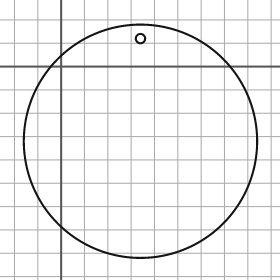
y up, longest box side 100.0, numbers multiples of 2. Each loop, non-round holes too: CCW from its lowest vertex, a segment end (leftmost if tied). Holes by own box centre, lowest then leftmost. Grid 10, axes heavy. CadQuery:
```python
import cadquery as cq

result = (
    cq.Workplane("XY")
    .moveTo(34.0, -32.0)
    .circle(50.0)
    .moveTo(34.0, 12.0)
    .circle(2.0)
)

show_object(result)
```